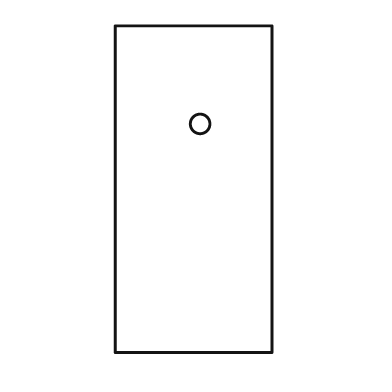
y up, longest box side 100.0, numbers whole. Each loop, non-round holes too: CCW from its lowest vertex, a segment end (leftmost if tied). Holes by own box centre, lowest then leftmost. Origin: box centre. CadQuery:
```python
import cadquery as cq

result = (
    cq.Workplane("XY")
    .moveTo(-24.0, -50.0)
    .lineTo(24.0, -50.0)
    .lineTo(24.0, 50.0)
    .lineTo(-24.0, 50.0)
    .close()
    .moveTo(2.0, 20.0)
    .circle(3.0)
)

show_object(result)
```